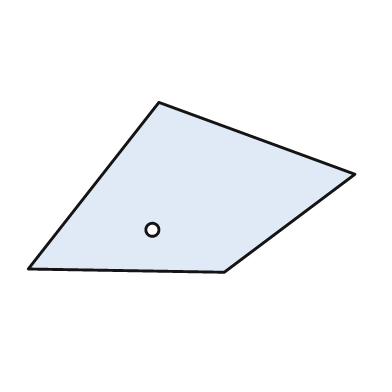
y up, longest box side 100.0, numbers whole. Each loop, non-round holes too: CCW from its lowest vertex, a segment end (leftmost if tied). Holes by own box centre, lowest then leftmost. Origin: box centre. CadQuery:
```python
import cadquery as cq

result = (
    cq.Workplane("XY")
    .moveTo(10.0, -26.0)
    .lineTo(50.0, 4.0)
    .lineTo(-10.0, 26.0)
    .lineTo(-50.0, -25.0)
    .close()
    .moveTo(-12.0, -13.0)
    .circle(2.0)
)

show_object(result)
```